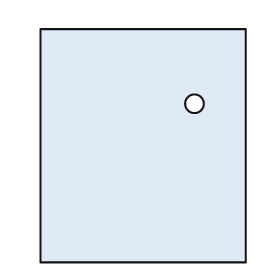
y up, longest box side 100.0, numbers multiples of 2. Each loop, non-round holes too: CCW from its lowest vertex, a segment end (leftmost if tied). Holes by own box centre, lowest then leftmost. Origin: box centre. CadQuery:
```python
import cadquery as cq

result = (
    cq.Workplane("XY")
    .moveTo(-44.0, -50.0)
    .lineTo(44.0, -50.0)
    .lineTo(44.0, 50.0)
    .lineTo(-44.0, 50.0)
    .close()
    .moveTo(22.0, 18.0)
    .circle(4.0)
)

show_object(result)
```